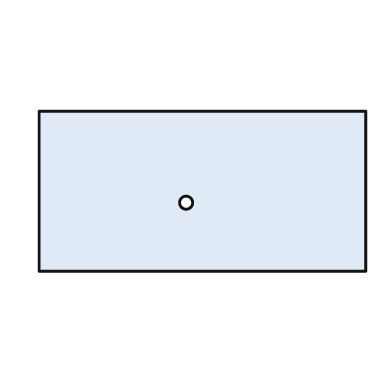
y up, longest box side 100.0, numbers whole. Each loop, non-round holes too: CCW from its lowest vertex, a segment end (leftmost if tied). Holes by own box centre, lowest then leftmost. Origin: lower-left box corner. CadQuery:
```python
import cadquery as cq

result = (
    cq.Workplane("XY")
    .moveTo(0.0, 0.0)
    .lineTo(100.0, 0.0)
    .lineTo(100.0, 49.0)
    .lineTo(0.0, 49.0)
    .close()
    .moveTo(45.0, 21.0)
    .circle(2.0)
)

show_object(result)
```